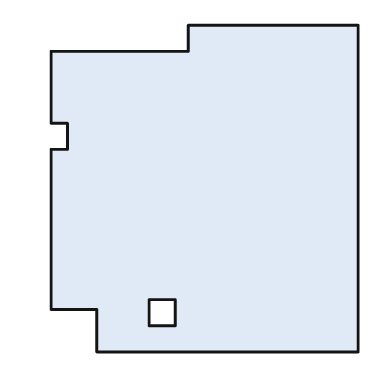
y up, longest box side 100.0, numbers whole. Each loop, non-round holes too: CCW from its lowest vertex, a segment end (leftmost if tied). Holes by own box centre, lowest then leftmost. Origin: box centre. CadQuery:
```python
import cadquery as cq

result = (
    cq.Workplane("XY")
    .moveTo(-33.0, -50.0)
    .lineTo(47.0, -50.0)
    .lineTo(47.0, 50.0)
    .lineTo(-5.0, 50.0)
    .lineTo(-5.0, 42.0)
    .lineTo(-47.0, 42.0)
    .lineTo(-47.0, 20.0)
    .lineTo(-42.0, 20.0)
    .lineTo(-42.0, 12.0)
    .lineTo(-47.0, 12.0)
    .lineTo(-47.0, -37.0)
    .lineTo(-33.0, -37.0)
    .close()
    .moveTo(-17.0, -42.0)
    .lineTo(-9.0, -42.0)
    .lineTo(-9.0, -34.0)
    .lineTo(-17.0, -34.0)
    .close()
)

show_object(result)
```